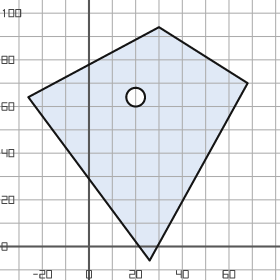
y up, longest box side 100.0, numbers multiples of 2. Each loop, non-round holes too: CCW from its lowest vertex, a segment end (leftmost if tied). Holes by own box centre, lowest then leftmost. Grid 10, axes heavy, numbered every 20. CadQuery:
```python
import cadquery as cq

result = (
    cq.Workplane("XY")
    .moveTo(26.0, -6.0)
    .lineTo(68.0, 70.0)
    .lineTo(30.0, 94.0)
    .lineTo(-26.0, 64.0)
    .close()
    .moveTo(20.0, 64.0)
    .circle(4.0)
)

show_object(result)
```